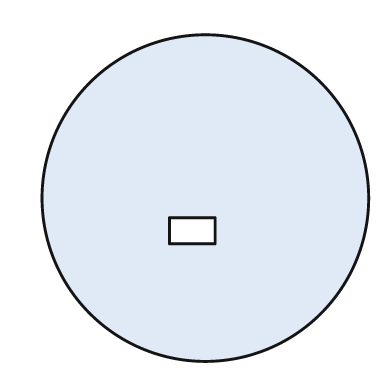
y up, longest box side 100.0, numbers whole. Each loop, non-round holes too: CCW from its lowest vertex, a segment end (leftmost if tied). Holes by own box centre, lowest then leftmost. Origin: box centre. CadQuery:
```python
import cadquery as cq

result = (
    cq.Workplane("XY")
    .moveTo(0.0, 0.0)
    .circle(50.0)
    .moveTo(-11.0, -14.0)
    .lineTo(3.0, -14.0)
    .lineTo(3.0, -6.0)
    .lineTo(-11.0, -6.0)
    .close()
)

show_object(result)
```